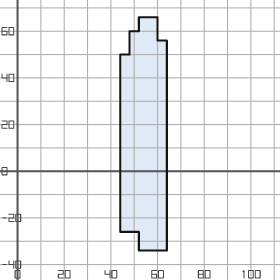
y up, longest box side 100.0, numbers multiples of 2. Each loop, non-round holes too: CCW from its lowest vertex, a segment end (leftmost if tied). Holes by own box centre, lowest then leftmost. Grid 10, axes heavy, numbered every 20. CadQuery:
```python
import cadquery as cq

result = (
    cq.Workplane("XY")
    .moveTo(52.0, -34.0)
    .lineTo(64.0, -34.0)
    .lineTo(64.0, 56.0)
    .lineTo(60.0, 56.0)
    .lineTo(60.0, 66.0)
    .lineTo(52.0, 66.0)
    .lineTo(52.0, 60.0)
    .lineTo(48.0, 60.0)
    .lineTo(48.0, 50.0)
    .lineTo(44.0, 50.0)
    .lineTo(44.0, -26.0)
    .lineTo(52.0, -26.0)
    .close()
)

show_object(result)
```